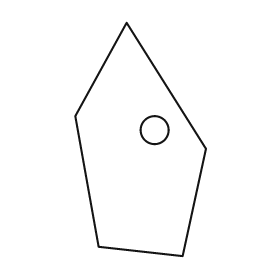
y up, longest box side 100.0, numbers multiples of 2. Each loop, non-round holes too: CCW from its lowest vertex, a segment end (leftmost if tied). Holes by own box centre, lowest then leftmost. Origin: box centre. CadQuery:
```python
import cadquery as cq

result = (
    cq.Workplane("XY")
    .moveTo(18.0, -50.0)
    .lineTo(28.0, -4.0)
    .lineTo(-6.0, 50.0)
    .lineTo(-28.0, 10.0)
    .lineTo(-18.0, -46.0)
    .close()
    .moveTo(6.0, 4.0)
    .circle(6.0)
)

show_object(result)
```